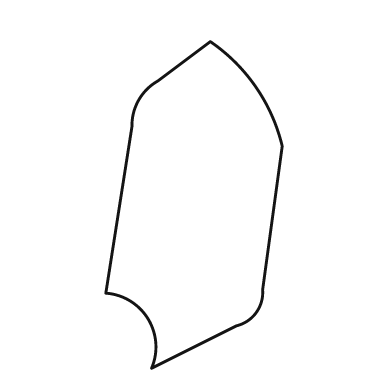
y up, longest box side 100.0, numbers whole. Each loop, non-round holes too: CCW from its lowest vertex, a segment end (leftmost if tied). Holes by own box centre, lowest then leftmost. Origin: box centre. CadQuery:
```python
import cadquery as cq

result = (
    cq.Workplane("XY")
    .moveTo(-13.0, -50.0)
    .lineTo(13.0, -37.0)
    .threePointArc((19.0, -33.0), (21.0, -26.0))
    .lineTo(27.0, 18.0)
    .threePointArc((19.0, 36.0), (5.0, 50.0))
    .lineTo(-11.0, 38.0)
    .threePointArc((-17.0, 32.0), (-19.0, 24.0))
    .lineTo(-27.0, -27.0)
    .threePointArc((-14.0, -35.0), (-13.0, -50.0))
    .close()
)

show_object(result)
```